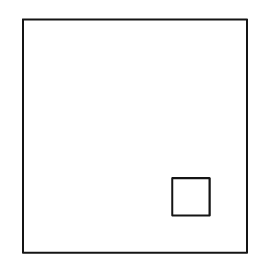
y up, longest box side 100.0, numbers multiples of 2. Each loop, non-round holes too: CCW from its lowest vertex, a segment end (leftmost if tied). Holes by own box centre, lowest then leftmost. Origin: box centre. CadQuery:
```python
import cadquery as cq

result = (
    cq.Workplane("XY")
    .moveTo(-48.0, -50.0)
    .lineTo(48.0, -50.0)
    .lineTo(48.0, 50.0)
    .lineTo(-48.0, 50.0)
    .close()
    .moveTo(16.0, -34.0)
    .lineTo(32.0, -34.0)
    .lineTo(32.0, -18.0)
    .lineTo(16.0, -18.0)
    .close()
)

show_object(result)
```